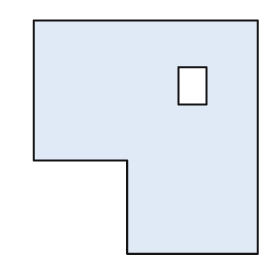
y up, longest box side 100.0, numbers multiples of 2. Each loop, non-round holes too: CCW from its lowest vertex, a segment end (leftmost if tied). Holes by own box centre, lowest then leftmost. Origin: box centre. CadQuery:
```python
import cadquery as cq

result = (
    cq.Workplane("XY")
    .moveTo(-8.0, -50.0)
    .lineTo(48.0, -50.0)
    .lineTo(48.0, 50.0)
    .lineTo(-48.0, 50.0)
    .lineTo(-48.0, -10.0)
    .lineTo(-8.0, -10.0)
    .close()
    .moveTo(14.0, 14.0)
    .lineTo(26.0, 14.0)
    .lineTo(26.0, 30.0)
    .lineTo(14.0, 30.0)
    .close()
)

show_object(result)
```